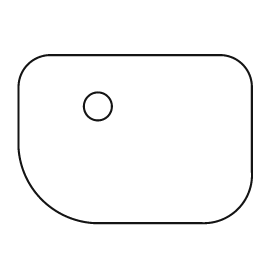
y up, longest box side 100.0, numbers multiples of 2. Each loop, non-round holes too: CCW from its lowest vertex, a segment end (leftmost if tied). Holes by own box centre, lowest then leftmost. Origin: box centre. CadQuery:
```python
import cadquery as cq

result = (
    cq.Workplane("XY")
    .moveTo(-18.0, -36.0)
    .lineTo(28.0, -36.0)
    .threePointArc((44.0, -30.0), (50.0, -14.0))
    .lineTo(50.0, 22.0)
    .threePointArc((46.0, 32.0), (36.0, 36.0))
    .lineTo(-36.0, 36.0)
    .threePointArc((-46.0, 32.0), (-50.0, 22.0))
    .lineTo(-50.0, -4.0)
    .threePointArc((-40.0, -26.0), (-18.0, -36.0))
    .close()
    .moveTo(-16.0, 14.0)
    .circle(6.0)
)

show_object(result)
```